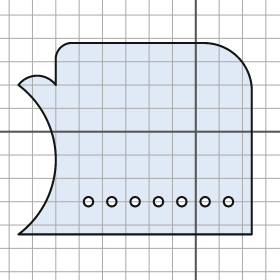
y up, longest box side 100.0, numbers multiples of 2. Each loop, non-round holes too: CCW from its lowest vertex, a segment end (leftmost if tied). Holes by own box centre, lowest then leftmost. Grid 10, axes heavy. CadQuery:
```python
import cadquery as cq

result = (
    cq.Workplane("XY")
    .moveTo(-76.0, -44.0)
    .lineTo(24.0, -44.0)
    .lineTo(24.0, 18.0)
    .threePointArc((18.0, 32.0), (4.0, 38.0))
    .lineTo(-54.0, 38.0)
    .threePointArc((-58.0, 36.0), (-60.0, 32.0))
    .lineTo(-60.0, 20.0)
    .threePointArc((-68.0, 24.0), (-76.0, 20.0))
    .threePointArc((-60.0, -12.0), (-76.0, -44.0))
    .close()
    .moveTo(-46.0, -30.0)
    .circle(2.0)
    .moveTo(-36.0, -30.0)
    .circle(2.0)
    .moveTo(-26.0, -30.0)
    .circle(2.0)
    .moveTo(-16.0, -30.0)
    .circle(2.0)
    .moveTo(-6.0, -30.0)
    .circle(2.0)
    .moveTo(4.0, -30.0)
    .circle(2.0)
    .moveTo(14.0, -30.0)
    .circle(2.0)
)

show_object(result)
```